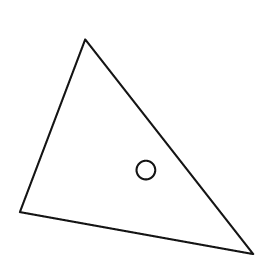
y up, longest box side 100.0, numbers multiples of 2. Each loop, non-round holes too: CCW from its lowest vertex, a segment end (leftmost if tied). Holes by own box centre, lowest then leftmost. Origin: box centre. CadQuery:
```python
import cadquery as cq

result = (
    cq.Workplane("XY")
    .moveTo(50.0, -46.0)
    .lineTo(-22.0, 46.0)
    .lineTo(-50.0, -28.0)
    .close()
    .moveTo(4.0, -10.0)
    .circle(4.0)
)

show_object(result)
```